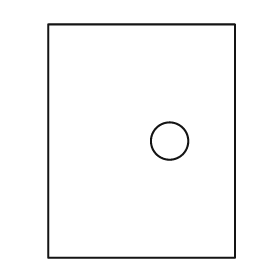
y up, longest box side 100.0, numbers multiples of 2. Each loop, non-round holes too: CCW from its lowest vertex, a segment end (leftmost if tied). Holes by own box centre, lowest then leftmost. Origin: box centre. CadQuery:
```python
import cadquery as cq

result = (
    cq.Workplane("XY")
    .moveTo(-40.0, -50.0)
    .lineTo(40.0, -50.0)
    .lineTo(40.0, 50.0)
    .lineTo(-40.0, 50.0)
    .close()
    .moveTo(12.0, 0.0)
    .circle(8.0)
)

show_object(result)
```